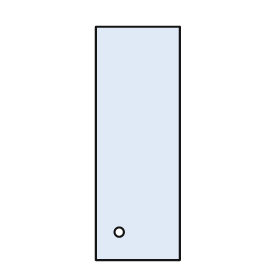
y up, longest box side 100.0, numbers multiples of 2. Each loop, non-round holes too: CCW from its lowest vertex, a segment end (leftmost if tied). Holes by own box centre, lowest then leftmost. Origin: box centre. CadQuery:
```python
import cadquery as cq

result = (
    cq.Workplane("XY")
    .moveTo(-18.0, -50.0)
    .lineTo(18.0, -50.0)
    .lineTo(18.0, 50.0)
    .lineTo(-18.0, 50.0)
    .close()
    .moveTo(-8.0, -38.0)
    .circle(2.0)
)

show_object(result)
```